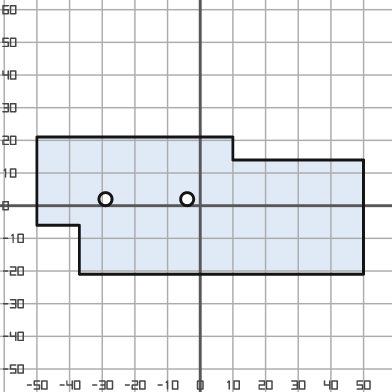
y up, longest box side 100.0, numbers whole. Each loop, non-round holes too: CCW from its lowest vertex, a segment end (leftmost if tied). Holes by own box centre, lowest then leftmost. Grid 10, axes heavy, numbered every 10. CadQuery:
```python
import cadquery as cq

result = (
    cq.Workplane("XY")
    .moveTo(-37.0, -21.0)
    .lineTo(50.0, -21.0)
    .lineTo(50.0, 14.0)
    .lineTo(10.0, 14.0)
    .lineTo(10.0, 21.0)
    .lineTo(-50.0, 21.0)
    .lineTo(-50.0, -6.0)
    .lineTo(-37.0, -6.0)
    .close()
    .moveTo(-29.0, 2.0)
    .circle(2.0)
    .moveTo(-4.0, 2.0)
    .circle(2.0)
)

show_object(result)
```